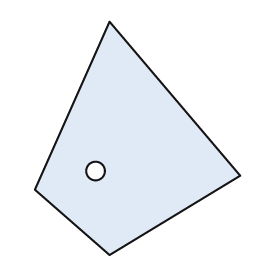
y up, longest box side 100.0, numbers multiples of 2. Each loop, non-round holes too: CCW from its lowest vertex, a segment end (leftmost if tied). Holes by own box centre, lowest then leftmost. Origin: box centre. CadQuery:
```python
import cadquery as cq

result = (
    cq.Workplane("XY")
    .moveTo(-12.0, -50.0)
    .lineTo(44.0, -16.0)
    .lineTo(-12.0, 50.0)
    .lineTo(-44.0, -22.0)
    .close()
    .moveTo(-18.0, -14.0)
    .circle(4.0)
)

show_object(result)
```